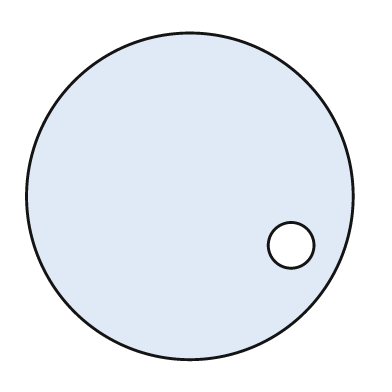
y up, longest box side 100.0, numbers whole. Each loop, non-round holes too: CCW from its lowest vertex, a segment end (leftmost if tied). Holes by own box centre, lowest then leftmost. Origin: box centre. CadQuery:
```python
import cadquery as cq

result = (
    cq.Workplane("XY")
    .moveTo(0.0, 0.0)
    .circle(50.0)
    .moveTo(31.0, -15.0)
    .circle(7.0)
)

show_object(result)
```